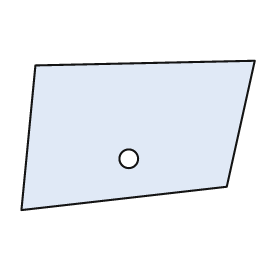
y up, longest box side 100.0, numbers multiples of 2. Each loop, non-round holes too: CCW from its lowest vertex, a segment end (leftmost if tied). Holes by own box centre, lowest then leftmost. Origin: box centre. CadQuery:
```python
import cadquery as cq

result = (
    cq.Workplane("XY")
    .moveTo(-50.0, -32.0)
    .lineTo(38.0, -22.0)
    .lineTo(50.0, 32.0)
    .lineTo(-44.0, 30.0)
    .close()
    .moveTo(-4.0, -10.0)
    .circle(4.0)
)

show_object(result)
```